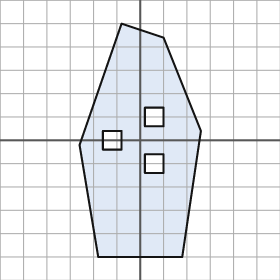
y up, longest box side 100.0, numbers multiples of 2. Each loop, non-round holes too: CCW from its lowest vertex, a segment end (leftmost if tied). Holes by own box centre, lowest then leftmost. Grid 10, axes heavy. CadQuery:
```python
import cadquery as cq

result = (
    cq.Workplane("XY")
    .moveTo(-18.0, -50.0)
    .lineTo(18.0, -50.0)
    .lineTo(26.0, 4.0)
    .lineTo(10.0, 44.0)
    .lineTo(-8.0, 50.0)
    .lineTo(-26.0, -2.0)
    .close()
    .moveTo(2.0, -14.0)
    .lineTo(10.0, -14.0)
    .lineTo(10.0, -6.0)
    .lineTo(2.0, -6.0)
    .close()
    .moveTo(-16.0, -4.0)
    .lineTo(-8.0, -4.0)
    .lineTo(-8.0, 4.0)
    .lineTo(-16.0, 4.0)
    .close()
    .moveTo(2.0, 6.0)
    .lineTo(10.0, 6.0)
    .lineTo(10.0, 14.0)
    .lineTo(2.0, 14.0)
    .close()
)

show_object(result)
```